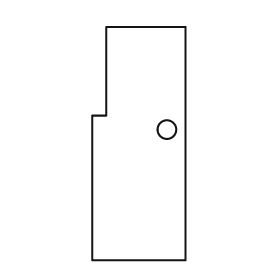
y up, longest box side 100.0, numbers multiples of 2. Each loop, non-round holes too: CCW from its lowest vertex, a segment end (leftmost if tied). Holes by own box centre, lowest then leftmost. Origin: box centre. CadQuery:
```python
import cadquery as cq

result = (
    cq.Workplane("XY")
    .moveTo(-20.0, -50.0)
    .lineTo(20.0, -50.0)
    .lineTo(20.0, 50.0)
    .lineTo(-14.0, 50.0)
    .lineTo(-14.0, 12.0)
    .lineTo(-20.0, 12.0)
    .close()
    .moveTo(12.0, 6.0)
    .circle(4.0)
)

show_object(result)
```